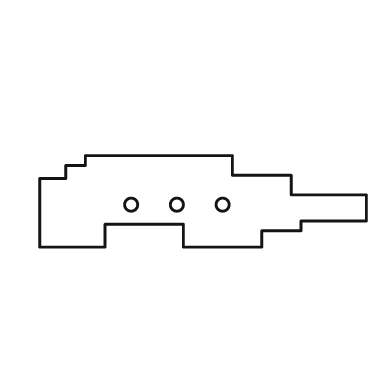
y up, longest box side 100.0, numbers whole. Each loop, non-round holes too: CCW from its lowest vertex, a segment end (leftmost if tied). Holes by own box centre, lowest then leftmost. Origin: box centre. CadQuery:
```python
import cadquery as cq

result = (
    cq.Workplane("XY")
    .moveTo(-50.0, -14.0)
    .lineTo(-30.0, -14.0)
    .lineTo(-30.0, -7.0)
    .lineTo(-6.0, -7.0)
    .lineTo(-6.0, -14.0)
    .lineTo(18.0, -14.0)
    .lineTo(18.0, -9.0)
    .lineTo(30.0, -9.0)
    .lineTo(30.0, -6.0)
    .lineTo(50.0, -6.0)
    .lineTo(50.0, 2.0)
    .lineTo(27.0, 2.0)
    .lineTo(27.0, 8.0)
    .lineTo(9.0, 8.0)
    .lineTo(9.0, 14.0)
    .lineTo(-36.0, 14.0)
    .lineTo(-36.0, 11.0)
    .lineTo(-42.0, 11.0)
    .lineTo(-42.0, 7.0)
    .lineTo(-50.0, 7.0)
    .close()
    .moveTo(-22.0, -1.0)
    .circle(2.0)
    .moveTo(-8.0, -1.0)
    .circle(2.0)
    .moveTo(6.0, -1.0)
    .circle(2.0)
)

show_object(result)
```